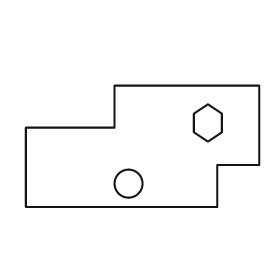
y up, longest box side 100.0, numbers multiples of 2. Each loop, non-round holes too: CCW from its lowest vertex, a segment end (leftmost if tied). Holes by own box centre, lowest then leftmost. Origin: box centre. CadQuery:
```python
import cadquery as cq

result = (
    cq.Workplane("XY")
    .moveTo(-50.0, -26.0)
    .lineTo(32.0, -26.0)
    .lineTo(32.0, -8.0)
    .lineTo(50.0, -8.0)
    .lineTo(50.0, 26.0)
    .lineTo(-12.0, 26.0)
    .lineTo(-12.0, 8.0)
    .lineTo(-50.0, 8.0)
    .close()
    .moveTo(-6.0, -16.0)
    .circle(6.0)
    .moveTo(28.0, 2.0)
    .lineTo(34.0, 6.0)
    .lineTo(34.0, 14.0)
    .lineTo(28.0, 18.0)
    .lineTo(22.0, 14.0)
    .lineTo(22.0, 6.0)
    .close()
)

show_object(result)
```